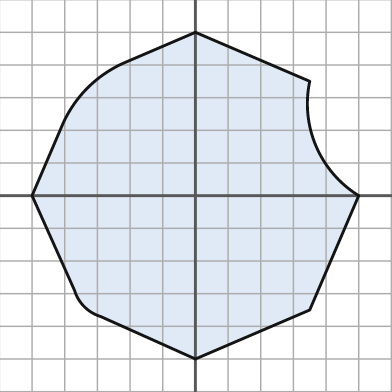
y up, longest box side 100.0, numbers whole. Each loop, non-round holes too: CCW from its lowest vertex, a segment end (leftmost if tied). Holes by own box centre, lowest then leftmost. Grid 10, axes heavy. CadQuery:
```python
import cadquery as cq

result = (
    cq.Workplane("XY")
    .moveTo(0.0, -50.0)
    .lineTo(35.0, -35.0)
    .lineTo(50.0, 0.0)
    .threePointArc((37.0, 15.0), (35.0, 35.0))
    .lineTo(0.0, 50.0)
    .lineTo(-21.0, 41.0)
    .threePointArc((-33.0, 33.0), (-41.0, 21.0))
    .lineTo(-50.0, 0.0)
    .lineTo(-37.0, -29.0)
    .threePointArc((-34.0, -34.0), (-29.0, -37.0))
    .close()
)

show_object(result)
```